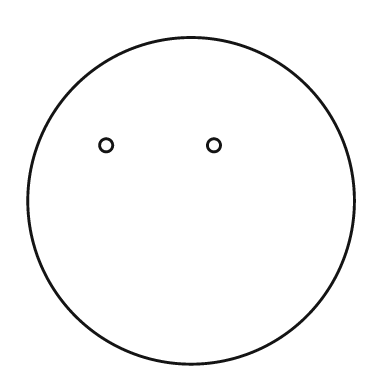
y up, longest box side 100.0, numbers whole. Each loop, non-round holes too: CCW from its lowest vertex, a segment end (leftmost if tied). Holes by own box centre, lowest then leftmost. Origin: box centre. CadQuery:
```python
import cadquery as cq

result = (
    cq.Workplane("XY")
    .moveTo(0.0, 0.0)
    .circle(50.0)
    .moveTo(-26.0, 17.0)
    .circle(2.0)
    .moveTo(7.0, 17.0)
    .circle(2.0)
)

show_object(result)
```